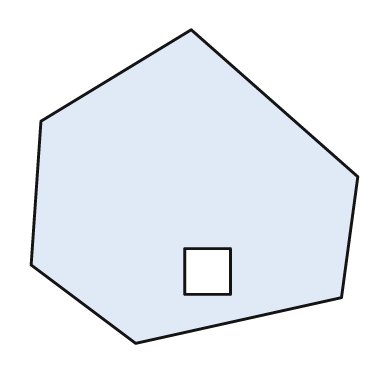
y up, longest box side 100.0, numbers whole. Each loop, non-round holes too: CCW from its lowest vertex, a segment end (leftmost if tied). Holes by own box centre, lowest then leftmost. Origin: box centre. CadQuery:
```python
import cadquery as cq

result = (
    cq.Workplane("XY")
    .moveTo(-18.0, -48.0)
    .lineTo(45.0, -34.0)
    .lineTo(50.0, 3.0)
    .lineTo(-1.0, 48.0)
    .lineTo(-47.0, 20.0)
    .lineTo(-50.0, -24.0)
    .close()
    .moveTo(-3.0, -33.0)
    .lineTo(11.0, -33.0)
    .lineTo(11.0, -19.0)
    .lineTo(-3.0, -19.0)
    .close()
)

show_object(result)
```